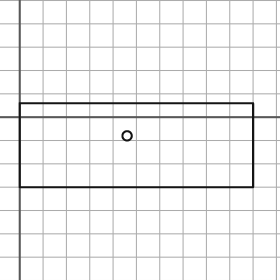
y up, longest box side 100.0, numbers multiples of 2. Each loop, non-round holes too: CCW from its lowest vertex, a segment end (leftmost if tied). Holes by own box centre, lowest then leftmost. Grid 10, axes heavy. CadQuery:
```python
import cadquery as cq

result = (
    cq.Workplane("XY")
    .moveTo(0.0, -30.0)
    .lineTo(100.0, -30.0)
    .lineTo(100.0, 6.0)
    .lineTo(0.0, 6.0)
    .close()
    .moveTo(46.0, -8.0)
    .circle(2.0)
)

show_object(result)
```